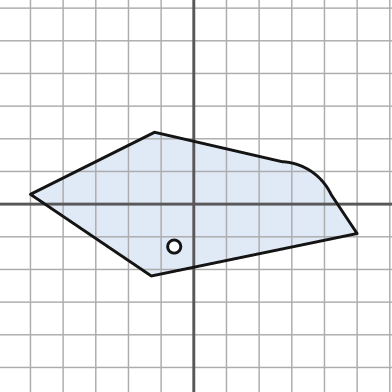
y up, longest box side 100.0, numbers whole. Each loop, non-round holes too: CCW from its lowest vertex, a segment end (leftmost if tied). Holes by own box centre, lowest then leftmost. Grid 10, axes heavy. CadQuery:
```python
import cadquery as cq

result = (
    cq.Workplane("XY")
    .moveTo(-13.0, -22.0)
    .lineTo(50.0, -9.0)
    .lineTo(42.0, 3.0)
    .threePointArc((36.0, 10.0), (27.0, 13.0))
    .lineTo(-12.0, 22.0)
    .lineTo(-50.0, 3.0)
    .close()
    .moveTo(-6.0, -13.0)
    .circle(2.0)
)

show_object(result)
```